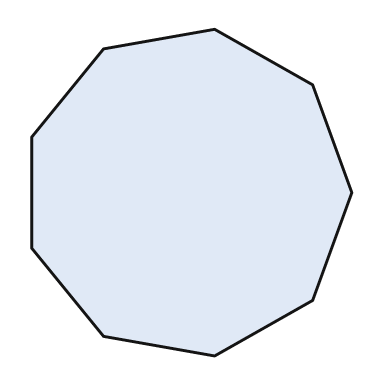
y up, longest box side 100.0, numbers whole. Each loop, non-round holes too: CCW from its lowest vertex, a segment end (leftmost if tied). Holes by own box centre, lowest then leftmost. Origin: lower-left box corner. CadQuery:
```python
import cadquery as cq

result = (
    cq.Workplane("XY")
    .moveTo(56.0, 0.0)
    .lineTo(86.0, 17.0)
    .lineTo(98.0, 50.0)
    .lineTo(86.0, 83.0)
    .lineTo(56.0, 100.0)
    .lineTo(22.0, 94.0)
    .lineTo(0.0, 67.0)
    .lineTo(0.0, 33.0)
    .lineTo(22.0, 6.0)
    .close()
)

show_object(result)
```